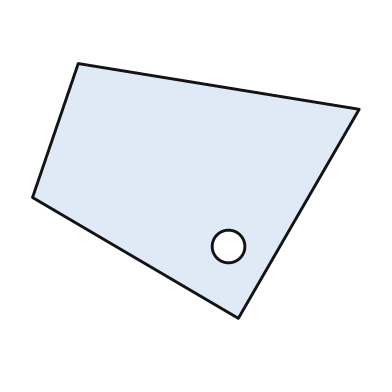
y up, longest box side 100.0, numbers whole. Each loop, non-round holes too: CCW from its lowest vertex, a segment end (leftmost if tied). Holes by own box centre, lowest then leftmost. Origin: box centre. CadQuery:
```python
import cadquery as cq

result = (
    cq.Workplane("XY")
    .moveTo(13.0, -39.0)
    .lineTo(50.0, 25.0)
    .lineTo(-36.0, 39.0)
    .lineTo(-50.0, -2.0)
    .close()
    .moveTo(10.0, -17.0)
    .circle(5.0)
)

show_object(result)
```